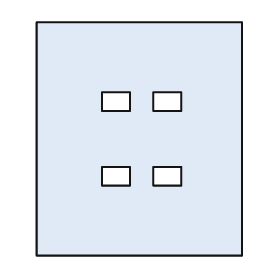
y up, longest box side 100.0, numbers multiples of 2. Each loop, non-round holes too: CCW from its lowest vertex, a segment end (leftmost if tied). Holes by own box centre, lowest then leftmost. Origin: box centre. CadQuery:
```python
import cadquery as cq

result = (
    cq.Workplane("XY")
    .moveTo(-44.0, -50.0)
    .lineTo(44.0, -50.0)
    .lineTo(44.0, 50.0)
    .lineTo(-44.0, 50.0)
    .close()
    .moveTo(-16.0, -20.0)
    .lineTo(-4.0, -20.0)
    .lineTo(-4.0, -12.0)
    .lineTo(-16.0, -12.0)
    .close()
    .moveTo(6.0, -20.0)
    .lineTo(18.0, -20.0)
    .lineTo(18.0, -12.0)
    .lineTo(6.0, -12.0)
    .close()
    .moveTo(-16.0, 12.0)
    .lineTo(-4.0, 12.0)
    .lineTo(-4.0, 20.0)
    .lineTo(-16.0, 20.0)
    .close()
    .moveTo(6.0, 12.0)
    .lineTo(18.0, 12.0)
    .lineTo(18.0, 20.0)
    .lineTo(6.0, 20.0)
    .close()
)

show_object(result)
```